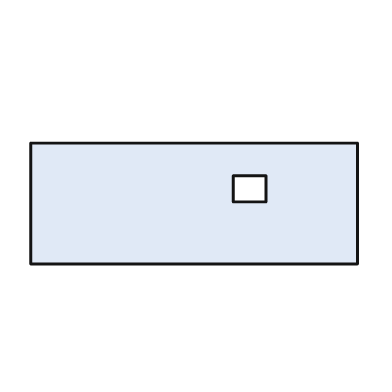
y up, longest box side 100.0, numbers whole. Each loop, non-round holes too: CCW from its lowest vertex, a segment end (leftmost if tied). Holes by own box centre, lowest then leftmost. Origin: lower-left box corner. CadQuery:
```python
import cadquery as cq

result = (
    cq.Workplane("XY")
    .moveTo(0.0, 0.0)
    .lineTo(100.0, 0.0)
    .lineTo(100.0, 37.0)
    .lineTo(0.0, 37.0)
    .close()
    .moveTo(62.0, 19.0)
    .lineTo(72.0, 19.0)
    .lineTo(72.0, 27.0)
    .lineTo(62.0, 27.0)
    .close()
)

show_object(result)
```